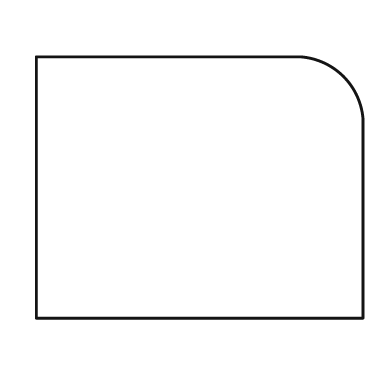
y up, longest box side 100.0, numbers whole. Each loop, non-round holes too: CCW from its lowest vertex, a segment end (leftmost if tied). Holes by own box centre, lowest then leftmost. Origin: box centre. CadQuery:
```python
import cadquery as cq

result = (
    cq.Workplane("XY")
    .moveTo(-50.0, -40.0)
    .lineTo(50.0, -40.0)
    .lineTo(50.0, 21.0)
    .threePointArc((44.0, 34.0), (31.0, 40.0))
    .lineTo(-50.0, 40.0)
    .close()
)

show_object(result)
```